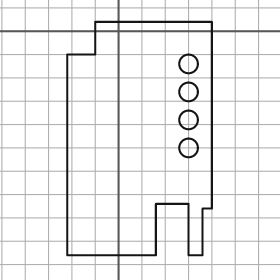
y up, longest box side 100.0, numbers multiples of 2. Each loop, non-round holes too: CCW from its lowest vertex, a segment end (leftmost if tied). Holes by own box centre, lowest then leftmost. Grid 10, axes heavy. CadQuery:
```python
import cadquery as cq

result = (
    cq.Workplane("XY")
    .moveTo(-22.0, -96.0)
    .lineTo(16.0, -96.0)
    .lineTo(16.0, -74.0)
    .lineTo(30.0, -74.0)
    .lineTo(30.0, -96.0)
    .lineTo(36.0, -96.0)
    .lineTo(36.0, -76.0)
    .lineTo(40.0, -76.0)
    .lineTo(40.0, 4.0)
    .lineTo(-10.0, 4.0)
    .lineTo(-10.0, -10.0)
    .lineTo(-22.0, -10.0)
    .close()
    .moveTo(30.0, -50.0)
    .circle(4.0)
    .moveTo(30.0, -38.0)
    .circle(4.0)
    .moveTo(30.0, -26.0)
    .circle(4.0)
    .moveTo(30.0, -14.0)
    .circle(4.0)
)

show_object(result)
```